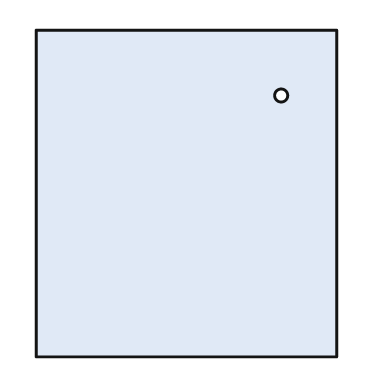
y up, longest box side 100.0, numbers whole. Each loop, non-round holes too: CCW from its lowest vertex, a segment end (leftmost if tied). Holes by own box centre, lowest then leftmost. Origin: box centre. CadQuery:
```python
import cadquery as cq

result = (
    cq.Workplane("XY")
    .moveTo(-46.0, -50.0)
    .lineTo(46.0, -50.0)
    .lineTo(46.0, 50.0)
    .lineTo(-46.0, 50.0)
    .close()
    .moveTo(29.0, 30.0)
    .circle(2.0)
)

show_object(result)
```